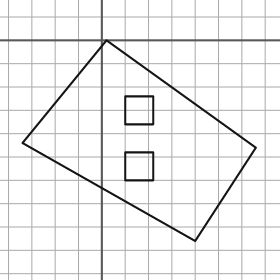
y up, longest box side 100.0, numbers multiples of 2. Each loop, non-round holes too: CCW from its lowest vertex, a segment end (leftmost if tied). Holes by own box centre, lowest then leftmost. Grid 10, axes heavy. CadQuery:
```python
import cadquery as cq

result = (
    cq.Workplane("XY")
    .moveTo(40.0, -86.0)
    .lineTo(66.0, -46.0)
    .lineTo(2.0, 0.0)
    .lineTo(-34.0, -44.0)
    .close()
    .moveTo(10.0, -60.0)
    .lineTo(22.0, -60.0)
    .lineTo(22.0, -48.0)
    .lineTo(10.0, -48.0)
    .close()
    .moveTo(10.0, -36.0)
    .lineTo(22.0, -36.0)
    .lineTo(22.0, -24.0)
    .lineTo(10.0, -24.0)
    .close()
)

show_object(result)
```